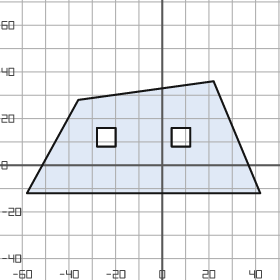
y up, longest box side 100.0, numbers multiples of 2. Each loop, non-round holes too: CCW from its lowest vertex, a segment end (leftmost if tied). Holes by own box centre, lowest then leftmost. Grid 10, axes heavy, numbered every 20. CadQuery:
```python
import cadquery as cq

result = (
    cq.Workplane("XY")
    .moveTo(-58.0, -12.0)
    .lineTo(42.0, -12.0)
    .lineTo(22.0, 36.0)
    .lineTo(-36.0, 28.0)
    .close()
    .moveTo(-28.0, 8.0)
    .lineTo(-20.0, 8.0)
    .lineTo(-20.0, 16.0)
    .lineTo(-28.0, 16.0)
    .close()
    .moveTo(4.0, 8.0)
    .lineTo(12.0, 8.0)
    .lineTo(12.0, 16.0)
    .lineTo(4.0, 16.0)
    .close()
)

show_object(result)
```